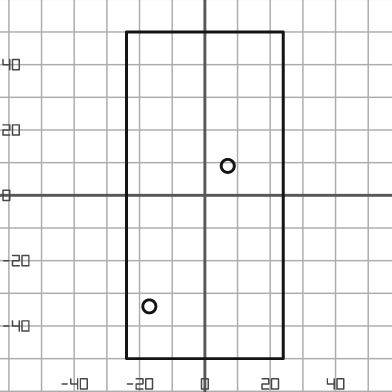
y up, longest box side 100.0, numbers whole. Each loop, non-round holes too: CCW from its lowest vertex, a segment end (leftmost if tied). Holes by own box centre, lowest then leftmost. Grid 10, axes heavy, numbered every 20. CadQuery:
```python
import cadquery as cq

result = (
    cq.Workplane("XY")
    .moveTo(-24.0, -50.0)
    .lineTo(24.0, -50.0)
    .lineTo(24.0, 50.0)
    .lineTo(-24.0, 50.0)
    .close()
    .moveTo(-17.0, -34.0)
    .circle(2.0)
    .moveTo(7.0, 9.0)
    .circle(2.0)
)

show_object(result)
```